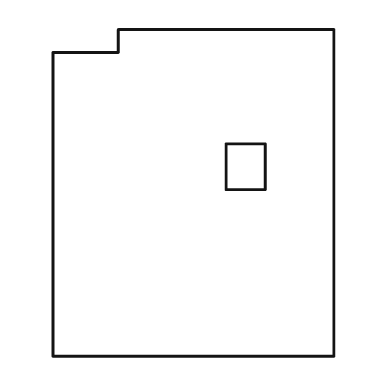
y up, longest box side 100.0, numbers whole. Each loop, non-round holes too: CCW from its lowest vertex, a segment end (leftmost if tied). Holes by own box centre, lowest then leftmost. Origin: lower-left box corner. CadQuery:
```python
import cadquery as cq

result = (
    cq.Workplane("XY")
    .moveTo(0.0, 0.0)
    .lineTo(86.0, 0.0)
    .lineTo(86.0, 100.0)
    .lineTo(20.0, 100.0)
    .lineTo(20.0, 93.0)
    .lineTo(0.0, 93.0)
    .close()
    .moveTo(53.0, 51.0)
    .lineTo(65.0, 51.0)
    .lineTo(65.0, 65.0)
    .lineTo(53.0, 65.0)
    .close()
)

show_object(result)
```